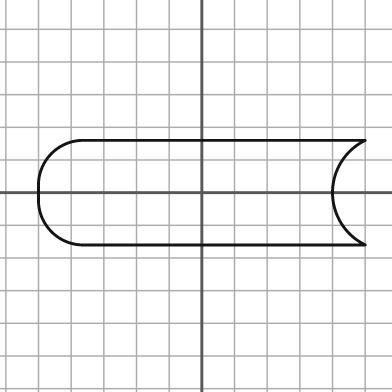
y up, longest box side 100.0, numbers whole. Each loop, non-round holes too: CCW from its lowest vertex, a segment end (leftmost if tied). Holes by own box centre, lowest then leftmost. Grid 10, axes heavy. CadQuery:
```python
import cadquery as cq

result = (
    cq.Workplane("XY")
    .moveTo(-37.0, -16.0)
    .lineTo(50.0, -16.0)
    .threePointArc((40.0, 0.0), (50.0, 16.0))
    .lineTo(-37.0, 16.0)
    .threePointArc((-46.0, 12.0), (-50.0, 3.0))
    .lineTo(-50.0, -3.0)
    .threePointArc((-46.0, -12.0), (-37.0, -16.0))
    .close()
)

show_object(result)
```